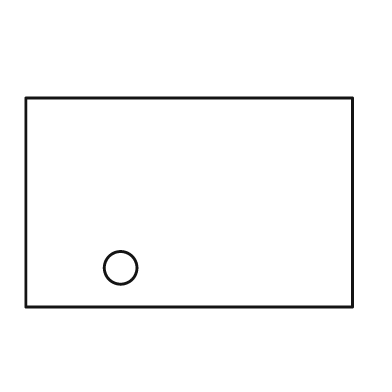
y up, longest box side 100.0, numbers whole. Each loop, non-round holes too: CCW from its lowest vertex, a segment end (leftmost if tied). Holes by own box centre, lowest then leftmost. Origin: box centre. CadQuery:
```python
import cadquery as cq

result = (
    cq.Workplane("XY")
    .moveTo(-50.0, -32.0)
    .lineTo(50.0, -32.0)
    .lineTo(50.0, 32.0)
    .lineTo(-50.0, 32.0)
    .close()
    .moveTo(-21.0, -20.0)
    .circle(5.0)
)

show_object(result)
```